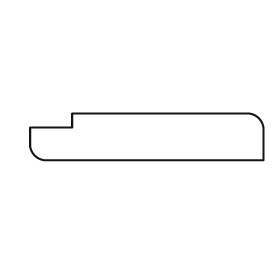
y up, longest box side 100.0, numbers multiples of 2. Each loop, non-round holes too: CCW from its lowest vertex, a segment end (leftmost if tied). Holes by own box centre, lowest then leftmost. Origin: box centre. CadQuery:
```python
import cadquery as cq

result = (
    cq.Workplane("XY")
    .moveTo(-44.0, -10.0)
    .lineTo(50.0, -10.0)
    .lineTo(50.0, 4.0)
    .threePointArc((48.0, 8.0), (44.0, 10.0))
    .lineTo(-32.0, 10.0)
    .lineTo(-32.0, 4.0)
    .lineTo(-50.0, 4.0)
    .lineTo(-50.0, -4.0)
    .threePointArc((-48.0, -8.0), (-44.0, -10.0))
    .close()
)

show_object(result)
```